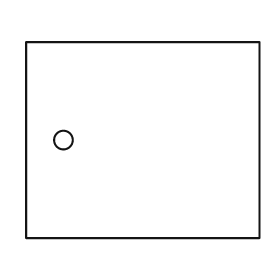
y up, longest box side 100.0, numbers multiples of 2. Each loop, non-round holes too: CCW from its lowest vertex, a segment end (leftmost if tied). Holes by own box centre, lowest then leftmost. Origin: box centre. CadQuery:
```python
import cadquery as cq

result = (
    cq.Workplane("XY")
    .moveTo(-50.0, -42.0)
    .lineTo(50.0, -42.0)
    .lineTo(50.0, 42.0)
    .lineTo(-50.0, 42.0)
    .close()
    .moveTo(-34.0, 0.0)
    .circle(4.0)
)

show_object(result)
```